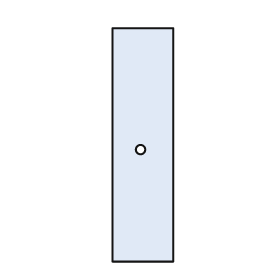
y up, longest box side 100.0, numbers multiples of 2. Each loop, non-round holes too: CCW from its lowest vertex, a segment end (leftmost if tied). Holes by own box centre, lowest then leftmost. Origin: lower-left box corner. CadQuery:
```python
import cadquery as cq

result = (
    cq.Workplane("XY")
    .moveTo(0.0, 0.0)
    .lineTo(26.0, 0.0)
    .lineTo(26.0, 100.0)
    .lineTo(0.0, 100.0)
    .close()
    .moveTo(12.0, 48.0)
    .circle(2.0)
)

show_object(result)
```